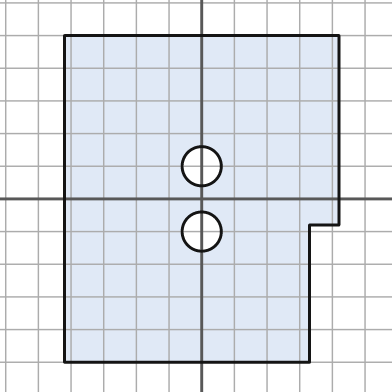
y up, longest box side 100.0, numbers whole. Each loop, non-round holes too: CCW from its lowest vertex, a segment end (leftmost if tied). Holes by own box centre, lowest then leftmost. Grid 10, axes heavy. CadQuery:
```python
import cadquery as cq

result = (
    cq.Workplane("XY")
    .moveTo(-42.0, -50.0)
    .lineTo(33.0, -50.0)
    .lineTo(33.0, -8.0)
    .lineTo(42.0, -8.0)
    .lineTo(42.0, 50.0)
    .lineTo(-42.0, 50.0)
    .close()
    .moveTo(0.0, -10.0)
    .circle(6.0)
    .moveTo(0.0, 10.0)
    .circle(6.0)
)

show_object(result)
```